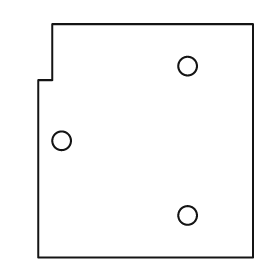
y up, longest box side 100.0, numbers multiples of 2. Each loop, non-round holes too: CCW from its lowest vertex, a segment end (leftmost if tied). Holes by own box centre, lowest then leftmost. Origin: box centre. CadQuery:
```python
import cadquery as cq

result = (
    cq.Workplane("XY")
    .moveTo(-46.0, -50.0)
    .lineTo(46.0, -50.0)
    .lineTo(46.0, 50.0)
    .lineTo(-40.0, 50.0)
    .lineTo(-40.0, 26.0)
    .lineTo(-46.0, 26.0)
    .close()
    .moveTo(18.0, -32.0)
    .circle(4.0)
    .moveTo(-36.0, 0.0)
    .circle(4.0)
    .moveTo(18.0, 32.0)
    .circle(4.0)
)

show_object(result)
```